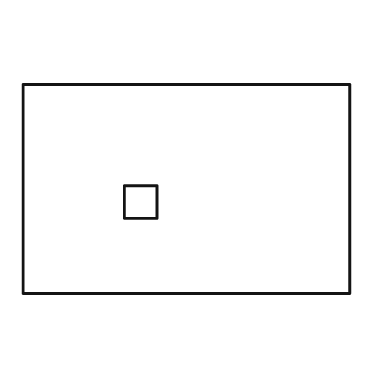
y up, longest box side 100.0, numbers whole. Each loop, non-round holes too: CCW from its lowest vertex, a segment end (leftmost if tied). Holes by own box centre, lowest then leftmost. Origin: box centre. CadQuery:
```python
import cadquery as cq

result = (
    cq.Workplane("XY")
    .moveTo(-50.0, -32.0)
    .lineTo(50.0, -32.0)
    .lineTo(50.0, 32.0)
    .lineTo(-50.0, 32.0)
    .close()
    .moveTo(-19.0, -9.0)
    .lineTo(-9.0, -9.0)
    .lineTo(-9.0, 1.0)
    .lineTo(-19.0, 1.0)
    .close()
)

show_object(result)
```